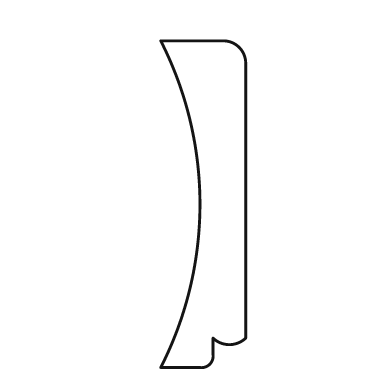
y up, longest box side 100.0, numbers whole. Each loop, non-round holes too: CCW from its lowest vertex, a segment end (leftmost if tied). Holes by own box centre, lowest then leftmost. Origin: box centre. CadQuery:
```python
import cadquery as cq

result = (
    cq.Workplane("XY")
    .moveTo(-13.0, -50.0)
    .lineTo(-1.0, -50.0)
    .threePointArc((2.0, -49.0), (3.0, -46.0))
    .lineTo(3.0, -41.0)
    .threePointArc((8.0, -43.0), (13.0, -41.0))
    .lineTo(13.0, 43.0)
    .threePointArc((11.0, 48.0), (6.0, 50.0))
    .lineTo(-13.0, 50.0)
    .threePointArc((-1.0, 0.0), (-13.0, -50.0))
    .close()
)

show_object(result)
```